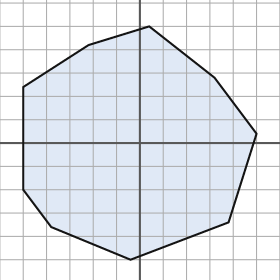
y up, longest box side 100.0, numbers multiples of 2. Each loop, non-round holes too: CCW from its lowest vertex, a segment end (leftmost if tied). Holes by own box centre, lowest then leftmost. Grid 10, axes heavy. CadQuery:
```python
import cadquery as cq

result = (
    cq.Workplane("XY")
    .moveTo(-4.0, -50.0)
    .lineTo(38.0, -34.0)
    .lineTo(50.0, 4.0)
    .lineTo(32.0, 28.0)
    .lineTo(4.0, 50.0)
    .lineTo(-22.0, 42.0)
    .lineTo(-50.0, 24.0)
    .lineTo(-50.0, -20.0)
    .lineTo(-38.0, -36.0)
    .close()
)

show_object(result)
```